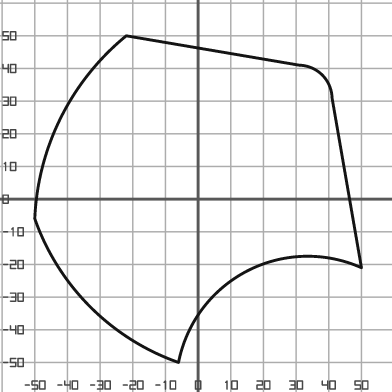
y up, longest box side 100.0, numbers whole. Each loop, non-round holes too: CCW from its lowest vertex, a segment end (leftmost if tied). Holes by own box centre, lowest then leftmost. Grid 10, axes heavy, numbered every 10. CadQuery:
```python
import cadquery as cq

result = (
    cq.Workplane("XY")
    .moveTo(-6.0, -50.0)
    .threePointArc((15.0, -22.0), (50.0, -21.0))
    .lineTo(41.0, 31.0)
    .threePointArc((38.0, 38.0), (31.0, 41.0))
    .lineTo(-22.0, 50.0)
    .threePointArc((-42.0, 25.0), (-50.0, -6.0))
    .threePointArc((-33.0, -33.0), (-6.0, -50.0))
    .close()
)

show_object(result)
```